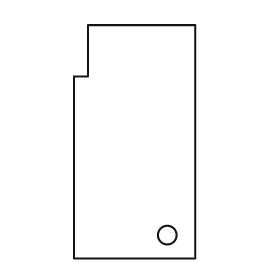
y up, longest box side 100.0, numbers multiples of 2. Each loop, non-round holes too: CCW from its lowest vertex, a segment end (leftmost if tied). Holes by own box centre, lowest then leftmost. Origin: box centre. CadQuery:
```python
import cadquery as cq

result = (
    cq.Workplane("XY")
    .moveTo(-26.0, -50.0)
    .lineTo(26.0, -50.0)
    .lineTo(26.0, 50.0)
    .lineTo(-20.0, 50.0)
    .lineTo(-20.0, 28.0)
    .lineTo(-26.0, 28.0)
    .close()
    .moveTo(14.0, -40.0)
    .circle(4.0)
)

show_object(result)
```